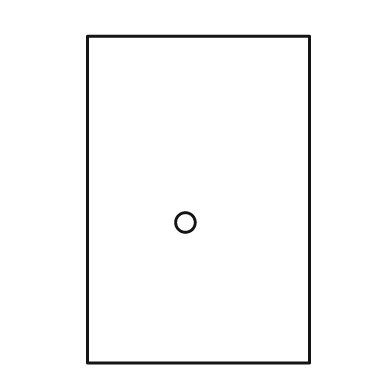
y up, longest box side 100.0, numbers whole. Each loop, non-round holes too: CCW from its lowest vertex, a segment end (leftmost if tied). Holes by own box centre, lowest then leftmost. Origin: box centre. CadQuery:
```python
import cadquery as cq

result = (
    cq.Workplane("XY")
    .moveTo(-34.0, -50.0)
    .lineTo(34.0, -50.0)
    .lineTo(34.0, 50.0)
    .lineTo(-34.0, 50.0)
    .close()
    .moveTo(-4.0, -7.0)
    .circle(3.0)
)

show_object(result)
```